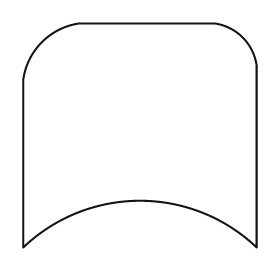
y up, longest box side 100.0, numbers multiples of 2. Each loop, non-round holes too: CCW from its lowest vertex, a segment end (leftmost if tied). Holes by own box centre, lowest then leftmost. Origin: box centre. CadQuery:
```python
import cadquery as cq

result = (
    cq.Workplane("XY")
    .moveTo(-50.0, -48.0)
    .threePointArc((0.0, -28.0), (50.0, -48.0))
    .lineTo(50.0, 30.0)
    .threePointArc((44.0, 42.0), (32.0, 48.0))
    .lineTo(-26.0, 48.0)
    .threePointArc((-42.0, 40.0), (-50.0, 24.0))
    .close()
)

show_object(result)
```